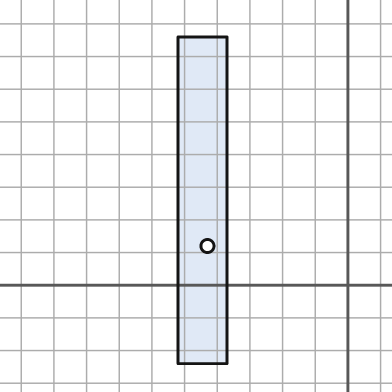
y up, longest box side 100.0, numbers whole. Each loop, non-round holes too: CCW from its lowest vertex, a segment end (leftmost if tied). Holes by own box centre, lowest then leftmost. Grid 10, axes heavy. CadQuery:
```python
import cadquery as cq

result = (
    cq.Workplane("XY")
    .moveTo(-52.0, -24.0)
    .lineTo(-37.0, -24.0)
    .lineTo(-37.0, 76.0)
    .lineTo(-52.0, 76.0)
    .close()
    .moveTo(-43.0, 12.0)
    .circle(2.0)
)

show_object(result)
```